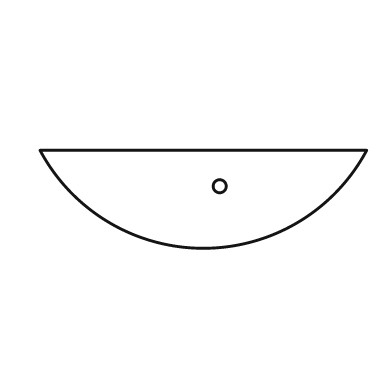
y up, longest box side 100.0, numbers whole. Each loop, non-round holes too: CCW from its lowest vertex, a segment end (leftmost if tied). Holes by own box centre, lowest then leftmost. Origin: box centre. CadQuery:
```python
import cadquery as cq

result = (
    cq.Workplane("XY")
    .moveTo(-50.0, 15.0)
    .threePointArc((0.0, -15.0), (50.0, 15.0))
    .close()
    .moveTo(5.0, 4.0)
    .circle(2.0)
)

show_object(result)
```